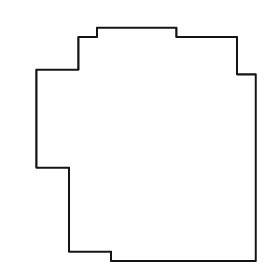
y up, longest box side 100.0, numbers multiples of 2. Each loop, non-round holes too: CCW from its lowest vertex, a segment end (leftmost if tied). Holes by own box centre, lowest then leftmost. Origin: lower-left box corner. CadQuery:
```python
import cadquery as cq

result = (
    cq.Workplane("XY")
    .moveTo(32.0, 0.0)
    .lineTo(94.0, 0.0)
    .lineTo(94.0, 80.0)
    .lineTo(86.0, 80.0)
    .lineTo(86.0, 96.0)
    .lineTo(60.0, 96.0)
    .lineTo(60.0, 100.0)
    .lineTo(26.0, 100.0)
    .lineTo(26.0, 96.0)
    .lineTo(18.0, 96.0)
    .lineTo(18.0, 82.0)
    .lineTo(0.0, 82.0)
    .lineTo(0.0, 40.0)
    .lineTo(14.0, 40.0)
    .lineTo(14.0, 4.0)
    .lineTo(32.0, 4.0)
    .close()
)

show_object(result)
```